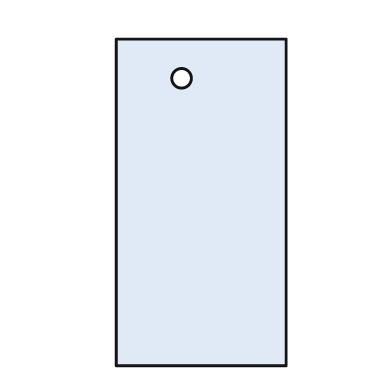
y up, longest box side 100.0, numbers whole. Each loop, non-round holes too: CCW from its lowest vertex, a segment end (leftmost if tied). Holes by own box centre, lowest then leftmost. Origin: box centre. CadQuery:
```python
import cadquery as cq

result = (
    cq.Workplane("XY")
    .moveTo(-26.0, -50.0)
    .lineTo(26.0, -50.0)
    .lineTo(26.0, 50.0)
    .lineTo(-26.0, 50.0)
    .close()
    .moveTo(-6.0, 38.0)
    .circle(3.0)
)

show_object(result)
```